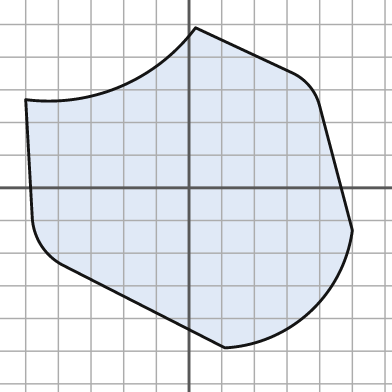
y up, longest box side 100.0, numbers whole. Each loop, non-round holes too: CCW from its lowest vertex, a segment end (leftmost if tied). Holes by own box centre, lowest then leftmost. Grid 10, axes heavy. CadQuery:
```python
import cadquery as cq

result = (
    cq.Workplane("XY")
    .moveTo(11.0, -49.0)
    .threePointArc((37.0, -38.0), (50.0, -13.0))
    .lineTo(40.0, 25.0)
    .threePointArc((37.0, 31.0), (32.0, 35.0))
    .lineTo(2.0, 49.0)
    .threePointArc((-21.0, 31.0), (-50.0, 27.0))
    .lineTo(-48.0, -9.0)
    .threePointArc((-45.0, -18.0), (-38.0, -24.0))
    .close()
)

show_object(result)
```